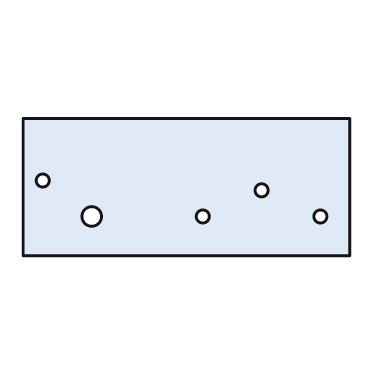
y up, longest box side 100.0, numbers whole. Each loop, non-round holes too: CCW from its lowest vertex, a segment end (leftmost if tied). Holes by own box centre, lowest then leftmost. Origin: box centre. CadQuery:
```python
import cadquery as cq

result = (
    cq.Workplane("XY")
    .moveTo(-50.0, -21.0)
    .lineTo(50.0, -21.0)
    .lineTo(50.0, 21.0)
    .lineTo(-50.0, 21.0)
    .close()
    .moveTo(-29.0, -9.0)
    .circle(3.0)
    .moveTo(5.0, -9.0)
    .circle(2.0)
    .moveTo(41.0, -9.0)
    .circle(2.0)
    .moveTo(23.0, -1.0)
    .circle(2.0)
    .moveTo(-44.0, 2.0)
    .circle(2.0)
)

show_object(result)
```